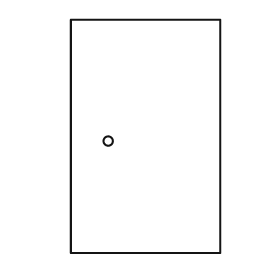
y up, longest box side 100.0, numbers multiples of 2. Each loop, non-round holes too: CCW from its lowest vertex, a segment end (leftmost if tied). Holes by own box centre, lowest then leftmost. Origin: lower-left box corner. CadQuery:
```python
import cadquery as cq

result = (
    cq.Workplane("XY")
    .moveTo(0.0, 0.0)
    .lineTo(64.0, 0.0)
    .lineTo(64.0, 100.0)
    .lineTo(0.0, 100.0)
    .close()
    .moveTo(16.0, 48.0)
    .circle(2.0)
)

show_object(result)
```